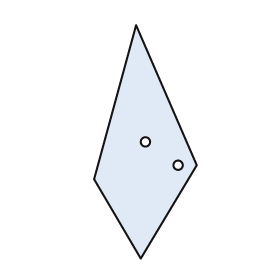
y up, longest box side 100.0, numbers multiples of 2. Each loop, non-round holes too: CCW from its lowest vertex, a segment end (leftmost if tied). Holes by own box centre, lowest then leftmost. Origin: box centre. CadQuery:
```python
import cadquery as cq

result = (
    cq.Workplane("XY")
    .moveTo(-2.0, -50.0)
    .lineTo(22.0, -10.0)
    .lineTo(-4.0, 50.0)
    .lineTo(-22.0, -16.0)
    .close()
    .moveTo(14.0, -10.0)
    .circle(2.0)
    .moveTo(0.0, 0.0)
    .circle(2.0)
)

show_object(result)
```